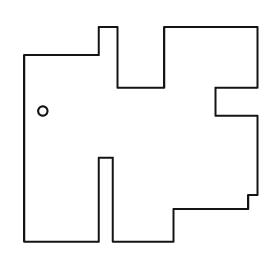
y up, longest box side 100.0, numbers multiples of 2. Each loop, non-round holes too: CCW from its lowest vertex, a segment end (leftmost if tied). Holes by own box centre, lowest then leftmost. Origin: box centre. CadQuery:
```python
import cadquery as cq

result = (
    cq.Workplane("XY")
    .moveTo(-50.0, -46.0)
    .lineTo(-18.0, -46.0)
    .lineTo(-18.0, -10.0)
    .lineTo(-12.0, -10.0)
    .lineTo(-12.0, -46.0)
    .lineTo(14.0, -46.0)
    .lineTo(14.0, -32.0)
    .lineTo(46.0, -32.0)
    .lineTo(46.0, -26.0)
    .lineTo(50.0, -26.0)
    .lineTo(50.0, 8.0)
    .lineTo(32.0, 8.0)
    .lineTo(32.0, 20.0)
    .lineTo(50.0, 20.0)
    .lineTo(50.0, 46.0)
    .lineTo(10.0, 46.0)
    .lineTo(10.0, 20.0)
    .lineTo(-10.0, 20.0)
    .lineTo(-10.0, 46.0)
    .lineTo(-18.0, 46.0)
    .lineTo(-18.0, 34.0)
    .lineTo(-50.0, 34.0)
    .close()
    .moveTo(-42.0, 10.0)
    .circle(2.0)
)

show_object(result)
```